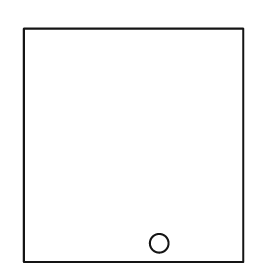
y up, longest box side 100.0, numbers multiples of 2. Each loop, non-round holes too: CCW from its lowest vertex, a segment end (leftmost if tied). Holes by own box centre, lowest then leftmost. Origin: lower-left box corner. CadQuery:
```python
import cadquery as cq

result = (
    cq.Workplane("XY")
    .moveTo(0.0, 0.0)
    .lineTo(94.0, 0.0)
    .lineTo(94.0, 100.0)
    .lineTo(0.0, 100.0)
    .close()
    .moveTo(58.0, 8.0)
    .circle(4.0)
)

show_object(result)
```